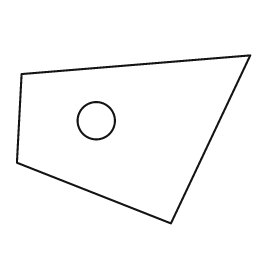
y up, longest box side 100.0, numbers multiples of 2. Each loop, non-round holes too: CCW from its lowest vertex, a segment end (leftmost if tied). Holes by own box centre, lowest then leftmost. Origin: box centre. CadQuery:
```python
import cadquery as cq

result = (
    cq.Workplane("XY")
    .moveTo(16.0, -36.0)
    .lineTo(50.0, 36.0)
    .lineTo(-48.0, 28.0)
    .lineTo(-50.0, -10.0)
    .close()
    .moveTo(-16.0, 8.0)
    .circle(8.0)
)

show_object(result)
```